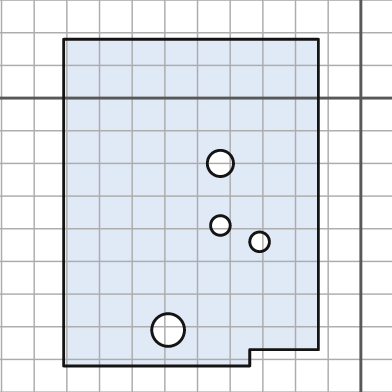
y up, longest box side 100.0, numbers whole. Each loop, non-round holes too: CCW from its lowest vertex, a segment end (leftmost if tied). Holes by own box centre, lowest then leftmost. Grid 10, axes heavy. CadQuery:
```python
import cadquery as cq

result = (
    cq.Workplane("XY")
    .moveTo(-91.0, -82.0)
    .lineTo(-34.0, -82.0)
    .lineTo(-34.0, -77.0)
    .lineTo(-13.0, -77.0)
    .lineTo(-13.0, 18.0)
    .lineTo(-91.0, 18.0)
    .close()
    .moveTo(-59.0, -71.0)
    .circle(5.0)
    .moveTo(-31.0, -44.0)
    .circle(3.0)
    .moveTo(-43.0, -39.0)
    .circle(3.0)
    .moveTo(-43.0, -20.0)
    .circle(4.0)
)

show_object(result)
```